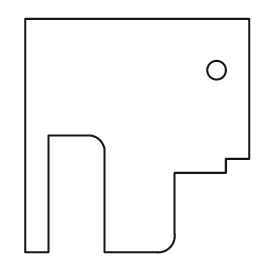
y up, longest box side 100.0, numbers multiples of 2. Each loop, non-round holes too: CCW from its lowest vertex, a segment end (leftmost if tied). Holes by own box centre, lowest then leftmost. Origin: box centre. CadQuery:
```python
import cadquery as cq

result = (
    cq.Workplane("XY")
    .moveTo(-48.0, -50.0)
    .lineTo(-38.0, -50.0)
    .lineTo(-38.0, 0.0)
    .lineTo(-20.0, 0.0)
    .threePointArc((-16.0, -2.0), (-14.0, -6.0))
    .lineTo(-14.0, -50.0)
    .lineTo(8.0, -50.0)
    .threePointArc((14.0, -48.0), (16.0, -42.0))
    .lineTo(16.0, -16.0)
    .lineTo(38.0, -16.0)
    .lineTo(38.0, -10.0)
    .lineTo(48.0, -10.0)
    .lineTo(48.0, 50.0)
    .lineTo(-48.0, 50.0)
    .close()
    .moveTo(34.0, 28.0)
    .circle(4.0)
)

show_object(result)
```